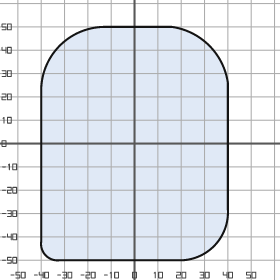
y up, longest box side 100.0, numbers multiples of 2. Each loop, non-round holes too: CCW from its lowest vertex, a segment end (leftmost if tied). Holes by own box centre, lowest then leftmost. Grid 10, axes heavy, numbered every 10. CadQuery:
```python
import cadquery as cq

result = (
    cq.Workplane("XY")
    .moveTo(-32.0, -50.0)
    .lineTo(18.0, -50.0)
    .threePointArc((34.0, -44.0), (40.0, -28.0))
    .lineTo(40.0, 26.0)
    .threePointArc((32.0, 42.0), (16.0, 50.0))
    .lineTo(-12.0, 50.0)
    .threePointArc((-32.0, 42.0), (-40.0, 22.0))
    .lineTo(-40.0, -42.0)
    .threePointArc((-38.0, -48.0), (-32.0, -50.0))
    .close()
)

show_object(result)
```